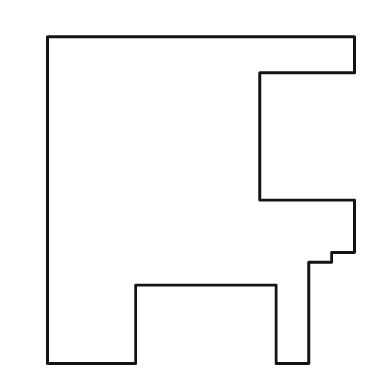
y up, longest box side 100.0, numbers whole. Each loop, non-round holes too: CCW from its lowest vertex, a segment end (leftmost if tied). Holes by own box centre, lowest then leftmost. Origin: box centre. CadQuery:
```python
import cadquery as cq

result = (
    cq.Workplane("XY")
    .moveTo(-47.0, -50.0)
    .lineTo(-20.0, -50.0)
    .lineTo(-20.0, -26.0)
    .lineTo(23.0, -26.0)
    .lineTo(23.0, -50.0)
    .lineTo(33.0, -50.0)
    .lineTo(33.0, -19.0)
    .lineTo(40.0, -19.0)
    .lineTo(40.0, -16.0)
    .lineTo(47.0, -16.0)
    .lineTo(47.0, 0.0)
    .lineTo(18.0, 0.0)
    .lineTo(18.0, 39.0)
    .lineTo(47.0, 39.0)
    .lineTo(47.0, 50.0)
    .lineTo(-47.0, 50.0)
    .close()
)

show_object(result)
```